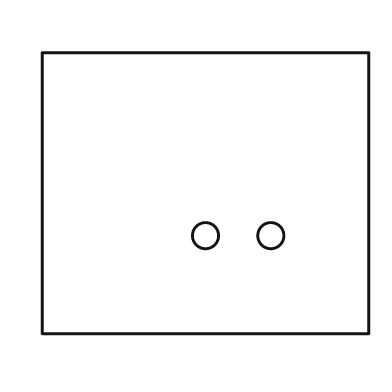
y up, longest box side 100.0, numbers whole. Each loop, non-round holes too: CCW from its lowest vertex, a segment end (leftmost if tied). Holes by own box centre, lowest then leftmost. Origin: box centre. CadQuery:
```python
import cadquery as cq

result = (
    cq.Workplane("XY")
    .moveTo(-50.0, -43.0)
    .lineTo(50.0, -43.0)
    .lineTo(50.0, 43.0)
    .lineTo(-50.0, 43.0)
    .close()
    .moveTo(0.0, -13.0)
    .circle(4.0)
    .moveTo(20.0, -13.0)
    .circle(4.0)
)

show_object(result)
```